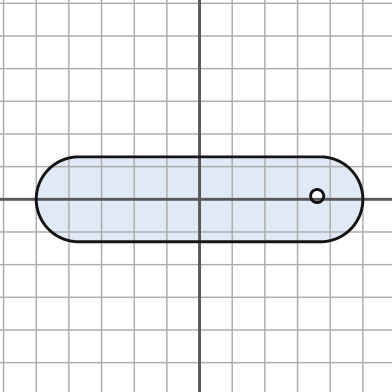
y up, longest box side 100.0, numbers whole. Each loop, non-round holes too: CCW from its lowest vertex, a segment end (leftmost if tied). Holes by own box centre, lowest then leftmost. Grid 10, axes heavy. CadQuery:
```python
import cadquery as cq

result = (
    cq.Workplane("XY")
    .moveTo(-37.0, -13.0)
    .lineTo(37.0, -13.0)
    .threePointArc((50.0, 0.0), (37.0, 13.0))
    .lineTo(-37.0, 13.0)
    .threePointArc((-50.0, 0.0), (-37.0, -13.0))
    .close()
    .moveTo(36.0, 1.0)
    .circle(2.0)
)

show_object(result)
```